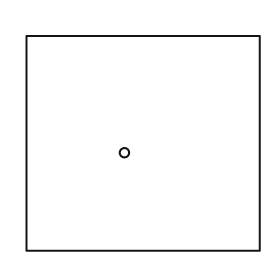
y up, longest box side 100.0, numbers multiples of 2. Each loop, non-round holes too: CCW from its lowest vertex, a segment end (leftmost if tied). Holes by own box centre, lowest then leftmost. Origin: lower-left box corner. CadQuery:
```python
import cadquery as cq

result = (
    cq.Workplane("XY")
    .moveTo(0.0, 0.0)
    .lineTo(100.0, 0.0)
    .lineTo(100.0, 92.0)
    .lineTo(0.0, 92.0)
    .close()
    .moveTo(42.0, 42.0)
    .circle(2.0)
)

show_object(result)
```